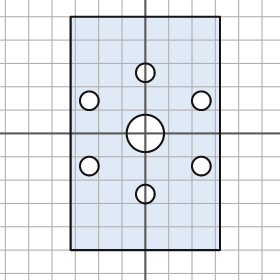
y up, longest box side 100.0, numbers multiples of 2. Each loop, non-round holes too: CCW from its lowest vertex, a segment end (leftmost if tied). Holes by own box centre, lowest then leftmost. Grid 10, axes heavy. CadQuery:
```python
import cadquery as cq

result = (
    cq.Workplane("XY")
    .moveTo(-32.0, -50.0)
    .lineTo(32.0, -50.0)
    .lineTo(32.0, 50.0)
    .lineTo(-32.0, 50.0)
    .close()
    .moveTo(0.0, -26.0)
    .circle(4.0)
    .moveTo(-24.0, -14.0)
    .circle(4.0)
    .moveTo(24.0, -14.0)
    .circle(4.0)
    .moveTo(0.0, 0.0)
    .circle(8.0)
    .moveTo(-24.0, 14.0)
    .circle(4.0)
    .moveTo(24.0, 14.0)
    .circle(4.0)
    .moveTo(0.0, 26.0)
    .circle(4.0)
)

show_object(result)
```